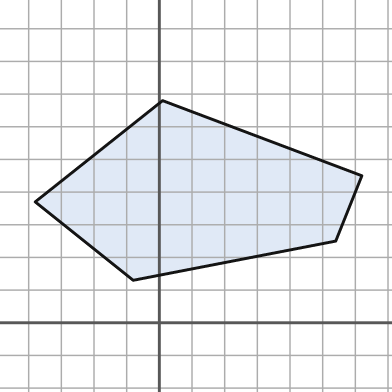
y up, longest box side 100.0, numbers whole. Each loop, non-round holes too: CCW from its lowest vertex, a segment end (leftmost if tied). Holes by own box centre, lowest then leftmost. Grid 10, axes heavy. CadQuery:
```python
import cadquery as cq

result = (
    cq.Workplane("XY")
    .moveTo(-8.0, 13.0)
    .lineTo(54.0, 25.0)
    .lineTo(62.0, 45.0)
    .lineTo(1.0, 68.0)
    .lineTo(-38.0, 37.0)
    .close()
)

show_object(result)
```